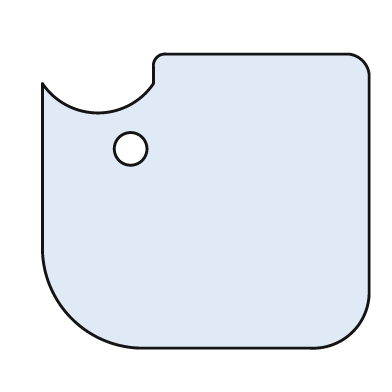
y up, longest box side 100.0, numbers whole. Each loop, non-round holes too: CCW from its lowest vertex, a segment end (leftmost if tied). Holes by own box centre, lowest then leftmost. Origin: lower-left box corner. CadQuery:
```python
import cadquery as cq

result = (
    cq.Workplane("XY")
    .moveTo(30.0, 0.0)
    .lineTo(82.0, 0.0)
    .threePointArc((95.0, 5.0), (100.0, 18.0))
    .lineTo(100.0, 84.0)
    .threePointArc((98.0, 88.0), (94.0, 90.0))
    .lineTo(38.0, 90.0)
    .threePointArc((35.0, 89.0), (34.0, 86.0))
    .lineTo(34.0, 81.0)
    .threePointArc((17.0, 72.0), (0.0, 81.0))
    .lineTo(0.0, 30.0)
    .threePointArc((9.0, 9.0), (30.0, 0.0))
    .close()
    .moveTo(27.0, 61.0)
    .circle(5.0)
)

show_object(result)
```